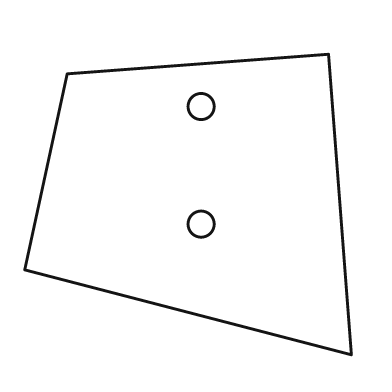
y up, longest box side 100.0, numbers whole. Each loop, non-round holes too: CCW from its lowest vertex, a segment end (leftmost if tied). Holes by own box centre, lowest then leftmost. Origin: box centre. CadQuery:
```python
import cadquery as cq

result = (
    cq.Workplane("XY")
    .moveTo(50.0, -46.0)
    .lineTo(43.0, 46.0)
    .lineTo(-37.0, 40.0)
    .lineTo(-50.0, -20.0)
    .close()
    .moveTo(4.0, -6.0)
    .circle(4.0)
    .moveTo(4.0, 30.0)
    .circle(4.0)
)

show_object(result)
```